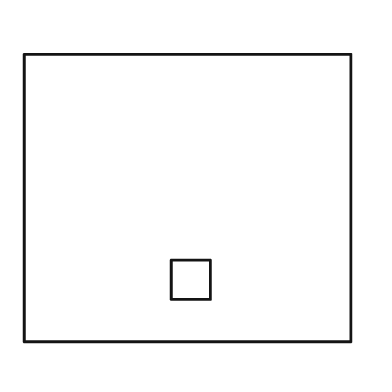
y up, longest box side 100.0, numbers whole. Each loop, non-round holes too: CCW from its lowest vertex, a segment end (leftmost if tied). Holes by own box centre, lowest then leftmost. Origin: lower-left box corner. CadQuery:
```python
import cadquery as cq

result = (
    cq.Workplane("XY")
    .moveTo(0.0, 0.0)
    .lineTo(100.0, 0.0)
    .lineTo(100.0, 88.0)
    .lineTo(0.0, 88.0)
    .close()
    .moveTo(45.0, 13.0)
    .lineTo(57.0, 13.0)
    .lineTo(57.0, 25.0)
    .lineTo(45.0, 25.0)
    .close()
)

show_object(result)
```